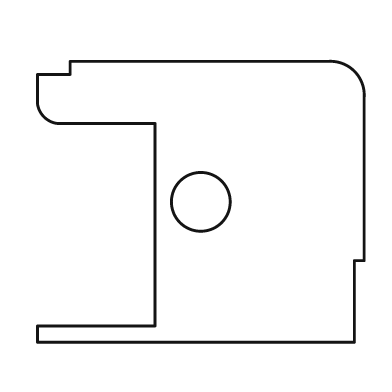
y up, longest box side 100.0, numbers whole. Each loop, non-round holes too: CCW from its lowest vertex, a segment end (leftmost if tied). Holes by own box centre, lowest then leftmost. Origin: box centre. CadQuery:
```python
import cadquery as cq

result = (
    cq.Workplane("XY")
    .moveTo(-50.0, -43.0)
    .lineTo(47.0, -43.0)
    .lineTo(47.0, -18.0)
    .lineTo(50.0, -18.0)
    .lineTo(50.0, 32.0)
    .threePointArc((47.0, 40.0), (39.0, 43.0))
    .lineTo(-40.0, 43.0)
    .lineTo(-40.0, 39.0)
    .lineTo(-50.0, 39.0)
    .lineTo(-50.0, 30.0)
    .threePointArc((-48.0, 26.0), (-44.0, 24.0))
    .lineTo(-14.0, 24.0)
    .lineTo(-14.0, -38.0)
    .lineTo(-50.0, -38.0)
    .close()
    .moveTo(0.0, 0.0)
    .circle(9.0)
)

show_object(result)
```